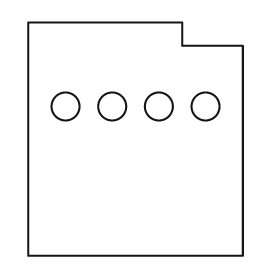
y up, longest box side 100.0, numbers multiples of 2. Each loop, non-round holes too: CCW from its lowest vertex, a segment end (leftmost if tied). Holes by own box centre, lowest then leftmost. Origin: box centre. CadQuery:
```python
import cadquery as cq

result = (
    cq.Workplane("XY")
    .moveTo(-46.0, -50.0)
    .lineTo(46.0, -50.0)
    .lineTo(46.0, 40.0)
    .lineTo(20.0, 40.0)
    .lineTo(20.0, 50.0)
    .lineTo(-46.0, 50.0)
    .close()
    .moveTo(-30.0, 14.0)
    .circle(6.0)
    .moveTo(-10.0, 14.0)
    .circle(6.0)
    .moveTo(10.0, 14.0)
    .circle(6.0)
    .moveTo(30.0, 14.0)
    .circle(6.0)
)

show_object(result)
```